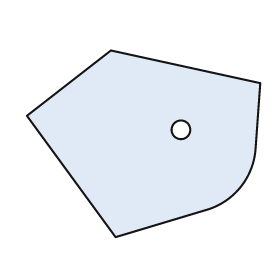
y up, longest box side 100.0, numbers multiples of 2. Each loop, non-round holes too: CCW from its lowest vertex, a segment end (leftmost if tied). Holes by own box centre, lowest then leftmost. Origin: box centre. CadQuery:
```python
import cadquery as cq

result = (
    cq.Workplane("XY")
    .moveTo(-12.0, -40.0)
    .lineTo(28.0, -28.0)
    .threePointArc((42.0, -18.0), (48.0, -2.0))
    .lineTo(50.0, 26.0)
    .lineTo(-14.0, 40.0)
    .lineTo(-50.0, 12.0)
    .close()
    .moveTo(16.0, 6.0)
    .circle(4.0)
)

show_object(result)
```